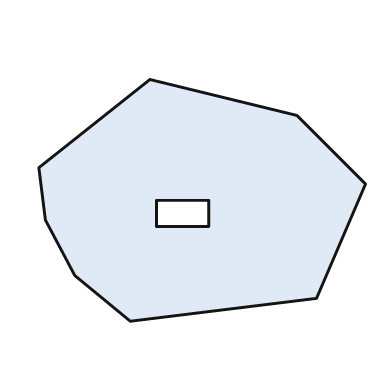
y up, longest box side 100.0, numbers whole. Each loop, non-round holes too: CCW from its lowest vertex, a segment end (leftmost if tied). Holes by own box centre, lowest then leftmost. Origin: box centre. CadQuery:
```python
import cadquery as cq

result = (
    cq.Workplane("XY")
    .moveTo(-22.0, -37.0)
    .lineTo(35.0, -30.0)
    .lineTo(50.0, 5.0)
    .lineTo(29.0, 26.0)
    .lineTo(-16.0, 37.0)
    .lineTo(-50.0, 10.0)
    .lineTo(-48.0, -6.0)
    .lineTo(-39.0, -23.0)
    .close()
    .moveTo(-14.0, -8.0)
    .lineTo(2.0, -8.0)
    .lineTo(2.0, 0.0)
    .lineTo(-14.0, 0.0)
    .close()
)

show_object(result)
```